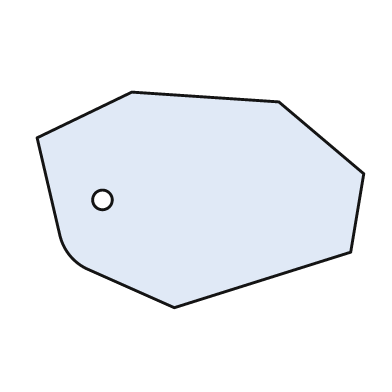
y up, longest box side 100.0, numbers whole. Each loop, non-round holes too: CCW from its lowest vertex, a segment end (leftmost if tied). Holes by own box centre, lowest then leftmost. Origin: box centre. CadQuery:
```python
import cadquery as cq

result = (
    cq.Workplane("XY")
    .moveTo(-8.0, -33.0)
    .lineTo(46.0, -16.0)
    .lineTo(50.0, 8.0)
    .lineTo(24.0, 30.0)
    .lineTo(-21.0, 33.0)
    .lineTo(-50.0, 19.0)
    .lineTo(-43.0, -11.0)
    .threePointArc((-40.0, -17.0), (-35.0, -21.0))
    .close()
    .moveTo(-30.0, 0.0)
    .circle(3.0)
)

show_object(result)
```